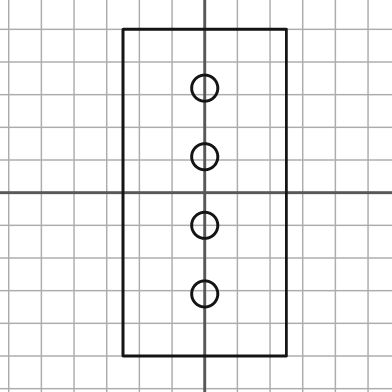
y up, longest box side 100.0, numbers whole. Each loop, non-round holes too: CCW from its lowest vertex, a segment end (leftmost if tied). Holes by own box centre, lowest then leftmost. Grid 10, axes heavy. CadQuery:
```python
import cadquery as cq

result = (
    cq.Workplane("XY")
    .moveTo(-25.0, -50.0)
    .lineTo(25.0, -50.0)
    .lineTo(25.0, 50.0)
    .lineTo(-25.0, 50.0)
    .close()
    .moveTo(0.0, -31.0)
    .circle(4.0)
    .moveTo(0.0, -10.0)
    .circle(4.0)
    .moveTo(0.0, 11.0)
    .circle(4.0)
    .moveTo(0.0, 32.0)
    .circle(4.0)
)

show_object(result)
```